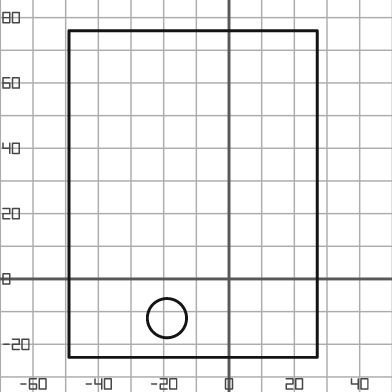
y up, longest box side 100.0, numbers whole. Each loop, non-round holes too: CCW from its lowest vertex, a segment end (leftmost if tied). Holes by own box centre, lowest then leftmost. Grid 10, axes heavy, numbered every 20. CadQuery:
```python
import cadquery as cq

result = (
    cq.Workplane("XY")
    .moveTo(-49.0, -24.0)
    .lineTo(27.0, -24.0)
    .lineTo(27.0, 76.0)
    .lineTo(-49.0, 76.0)
    .close()
    .moveTo(-19.0, -12.0)
    .circle(6.0)
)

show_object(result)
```